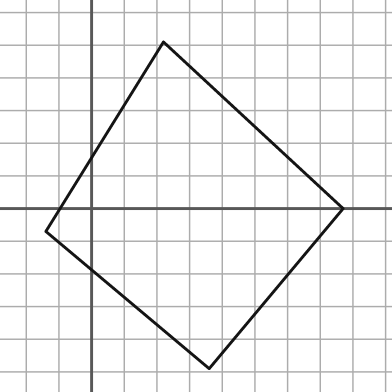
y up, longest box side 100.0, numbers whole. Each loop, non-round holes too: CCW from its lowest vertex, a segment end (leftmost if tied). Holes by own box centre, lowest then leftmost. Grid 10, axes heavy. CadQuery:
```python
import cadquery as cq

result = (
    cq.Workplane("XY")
    .moveTo(36.0, -49.0)
    .lineTo(77.0, 0.0)
    .lineTo(22.0, 51.0)
    .lineTo(-14.0, -7.0)
    .close()
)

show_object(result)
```